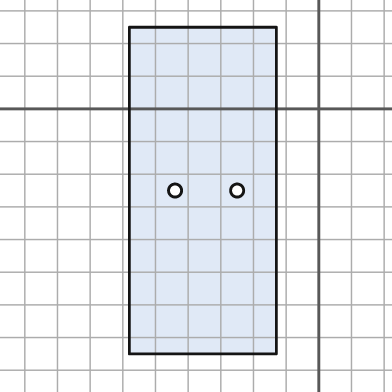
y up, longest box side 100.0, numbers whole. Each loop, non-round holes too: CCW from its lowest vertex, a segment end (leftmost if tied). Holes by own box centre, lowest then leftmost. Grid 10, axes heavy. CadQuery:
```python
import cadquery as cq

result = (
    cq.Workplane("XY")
    .moveTo(-58.0, -75.0)
    .lineTo(-13.0, -75.0)
    .lineTo(-13.0, 25.0)
    .lineTo(-58.0, 25.0)
    .close()
    .moveTo(-44.0, -25.0)
    .circle(2.0)
    .moveTo(-25.0, -25.0)
    .circle(2.0)
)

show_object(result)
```